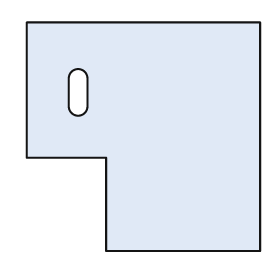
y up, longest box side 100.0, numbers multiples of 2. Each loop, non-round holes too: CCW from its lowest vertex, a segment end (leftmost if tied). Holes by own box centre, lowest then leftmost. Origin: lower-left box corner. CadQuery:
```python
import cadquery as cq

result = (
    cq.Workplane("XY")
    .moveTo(34.0, 0.0)
    .lineTo(100.0, 0.0)
    .lineTo(100.0, 98.0)
    .lineTo(0.0, 98.0)
    .lineTo(0.0, 40.0)
    .lineTo(34.0, 40.0)
    .close()
    .moveTo(18.0, 62.0)
    .threePointArc((22.0, 58.0), (26.0, 62.0))
    .lineTo(26.0, 74.0)
    .threePointArc((22.0, 78.0), (18.0, 74.0))
    .close()
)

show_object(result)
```